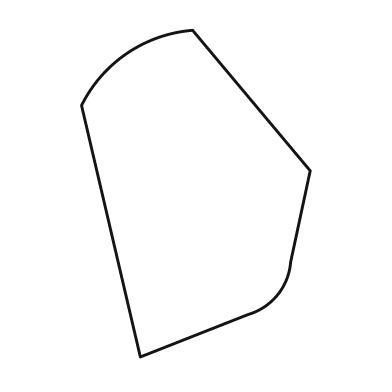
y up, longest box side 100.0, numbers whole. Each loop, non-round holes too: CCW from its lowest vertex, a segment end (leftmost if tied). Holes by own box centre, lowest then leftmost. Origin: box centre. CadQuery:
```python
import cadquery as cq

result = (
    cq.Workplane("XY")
    .moveTo(-17.0, -50.0)
    .lineTo(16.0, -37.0)
    .threePointArc((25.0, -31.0), (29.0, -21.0))
    .lineTo(35.0, 7.0)
    .lineTo(-1.0, 50.0)
    .threePointArc((-21.0, 43.0), (-35.0, 27.0))
    .close()
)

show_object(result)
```